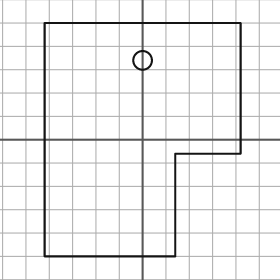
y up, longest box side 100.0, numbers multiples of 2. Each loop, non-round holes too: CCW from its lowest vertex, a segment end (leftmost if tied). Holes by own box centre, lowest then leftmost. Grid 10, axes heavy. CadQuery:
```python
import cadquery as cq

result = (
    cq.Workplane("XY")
    .moveTo(-42.0, -50.0)
    .lineTo(14.0, -50.0)
    .lineTo(14.0, -6.0)
    .lineTo(42.0, -6.0)
    .lineTo(42.0, 50.0)
    .lineTo(-42.0, 50.0)
    .close()
    .moveTo(0.0, 34.0)
    .circle(4.0)
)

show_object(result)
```